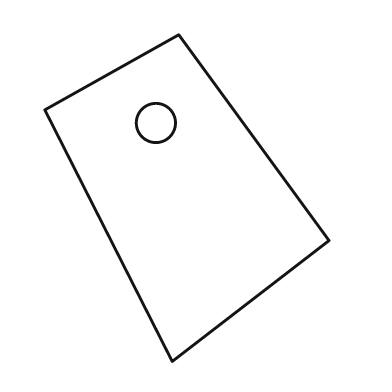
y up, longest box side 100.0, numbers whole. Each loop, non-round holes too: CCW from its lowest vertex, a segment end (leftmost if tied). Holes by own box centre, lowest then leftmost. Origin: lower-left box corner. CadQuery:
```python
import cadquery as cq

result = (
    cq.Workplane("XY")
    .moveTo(39.0, 0.0)
    .lineTo(87.0, 37.0)
    .lineTo(41.0, 100.0)
    .lineTo(0.0, 77.0)
    .close()
    .moveTo(34.0, 73.0)
    .circle(6.0)
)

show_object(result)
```